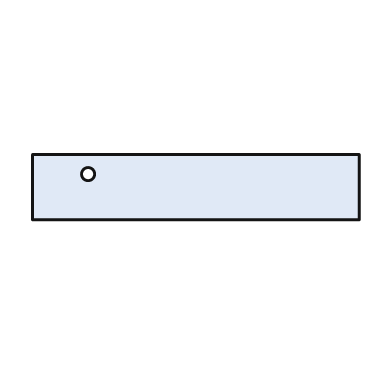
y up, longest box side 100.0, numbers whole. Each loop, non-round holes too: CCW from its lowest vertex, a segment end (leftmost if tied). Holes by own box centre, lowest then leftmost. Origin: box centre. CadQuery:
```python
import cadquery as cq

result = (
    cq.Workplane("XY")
    .moveTo(-50.0, -10.0)
    .lineTo(50.0, -10.0)
    .lineTo(50.0, 10.0)
    .lineTo(-50.0, 10.0)
    .close()
    .moveTo(-33.0, 4.0)
    .circle(2.0)
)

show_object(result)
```